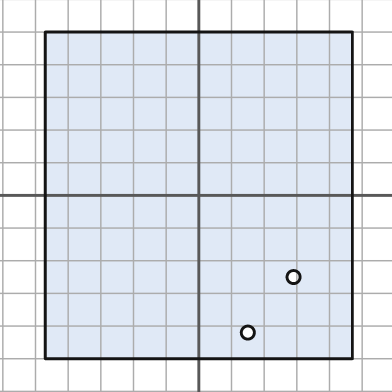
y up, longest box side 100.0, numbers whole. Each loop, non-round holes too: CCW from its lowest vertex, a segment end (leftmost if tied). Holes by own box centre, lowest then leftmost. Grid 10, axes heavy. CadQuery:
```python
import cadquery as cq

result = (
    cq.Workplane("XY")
    .moveTo(-47.0, -50.0)
    .lineTo(47.0, -50.0)
    .lineTo(47.0, 50.0)
    .lineTo(-47.0, 50.0)
    .close()
    .moveTo(15.0, -42.0)
    .circle(2.0)
    .moveTo(29.0, -25.0)
    .circle(2.0)
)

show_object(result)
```